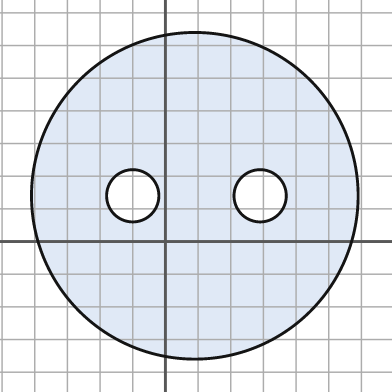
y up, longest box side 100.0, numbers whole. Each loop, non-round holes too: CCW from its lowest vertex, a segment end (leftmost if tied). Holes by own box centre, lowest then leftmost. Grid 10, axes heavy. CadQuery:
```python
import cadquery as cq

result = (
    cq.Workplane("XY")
    .moveTo(9.0, 14.0)
    .circle(50.0)
    .moveTo(-10.0, 14.0)
    .circle(8.0)
    .moveTo(29.0, 14.0)
    .circle(8.0)
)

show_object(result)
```